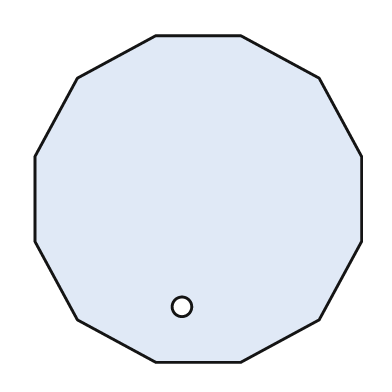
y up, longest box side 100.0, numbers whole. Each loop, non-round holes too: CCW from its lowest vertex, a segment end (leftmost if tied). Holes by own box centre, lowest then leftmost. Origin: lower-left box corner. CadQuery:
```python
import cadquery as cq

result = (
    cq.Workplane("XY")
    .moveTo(37.0, 0.0)
    .lineTo(63.0, 0.0)
    .lineTo(87.0, 13.0)
    .lineTo(100.0, 37.0)
    .lineTo(100.0, 63.0)
    .lineTo(87.0, 87.0)
    .lineTo(63.0, 100.0)
    .lineTo(37.0, 100.0)
    .lineTo(13.0, 87.0)
    .lineTo(0.0, 63.0)
    .lineTo(0.0, 37.0)
    .lineTo(13.0, 13.0)
    .close()
    .moveTo(45.0, 17.0)
    .circle(3.0)
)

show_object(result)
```